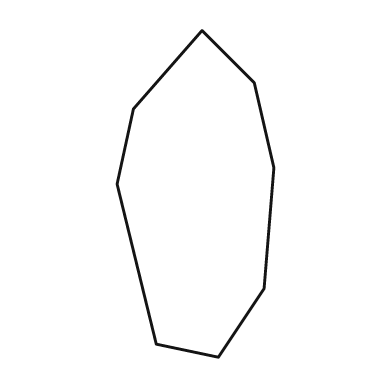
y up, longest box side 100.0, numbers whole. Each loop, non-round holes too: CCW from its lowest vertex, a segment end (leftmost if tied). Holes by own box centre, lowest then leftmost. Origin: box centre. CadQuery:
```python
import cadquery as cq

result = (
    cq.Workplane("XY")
    .moveTo(7.0, -50.0)
    .lineTo(21.0, -29.0)
    .lineTo(24.0, 8.0)
    .lineTo(18.0, 34.0)
    .lineTo(2.0, 50.0)
    .lineTo(-19.0, 26.0)
    .lineTo(-24.0, 3.0)
    .lineTo(-12.0, -46.0)
    .close()
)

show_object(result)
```